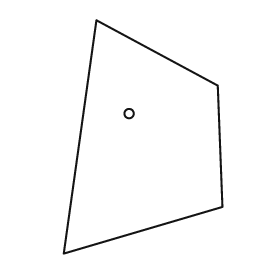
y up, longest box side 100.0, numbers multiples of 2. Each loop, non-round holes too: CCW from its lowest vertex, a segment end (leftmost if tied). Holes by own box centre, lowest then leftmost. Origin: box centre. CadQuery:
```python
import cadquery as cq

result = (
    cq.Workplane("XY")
    .moveTo(-34.0, -50.0)
    .lineTo(34.0, -30.0)
    .lineTo(32.0, 22.0)
    .lineTo(-20.0, 50.0)
    .close()
    .moveTo(-6.0, 10.0)
    .circle(2.0)
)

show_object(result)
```